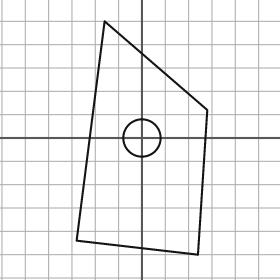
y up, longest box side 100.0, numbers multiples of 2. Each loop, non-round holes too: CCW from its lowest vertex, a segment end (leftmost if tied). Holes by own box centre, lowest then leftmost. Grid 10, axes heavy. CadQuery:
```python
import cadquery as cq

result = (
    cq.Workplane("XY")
    .moveTo(24.0, -50.0)
    .lineTo(28.0, 12.0)
    .lineTo(-16.0, 50.0)
    .lineTo(-28.0, -44.0)
    .close()
    .moveTo(0.0, 0.0)
    .circle(8.0)
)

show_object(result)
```